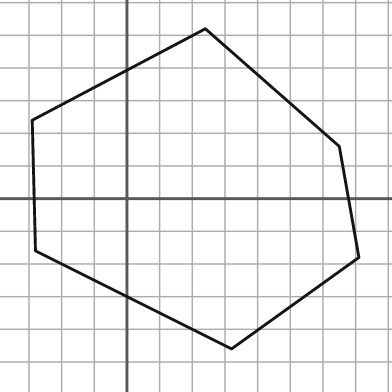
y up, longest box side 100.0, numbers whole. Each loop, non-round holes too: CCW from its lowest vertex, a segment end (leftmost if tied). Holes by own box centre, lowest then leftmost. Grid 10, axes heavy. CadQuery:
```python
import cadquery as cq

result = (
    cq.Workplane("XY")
    .moveTo(32.0, -46.0)
    .lineTo(71.0, -18.0)
    .lineTo(65.0, 16.0)
    .lineTo(24.0, 52.0)
    .lineTo(-29.0, 24.0)
    .lineTo(-28.0, -16.0)
    .close()
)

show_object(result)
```